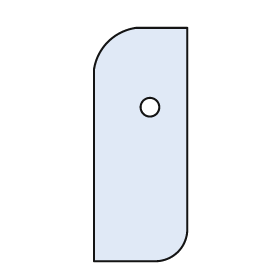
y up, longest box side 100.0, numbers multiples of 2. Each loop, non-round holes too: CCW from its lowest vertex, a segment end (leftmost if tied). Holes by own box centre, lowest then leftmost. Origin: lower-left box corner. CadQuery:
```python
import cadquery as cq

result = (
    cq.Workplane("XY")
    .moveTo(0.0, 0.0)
    .lineTo(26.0, 0.0)
    .threePointArc((36.0, 4.0), (40.0, 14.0))
    .lineTo(40.0, 100.0)
    .lineTo(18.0, 100.0)
    .threePointArc((6.0, 94.0), (0.0, 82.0))
    .close()
    .moveTo(24.0, 66.0)
    .circle(4.0)
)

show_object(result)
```